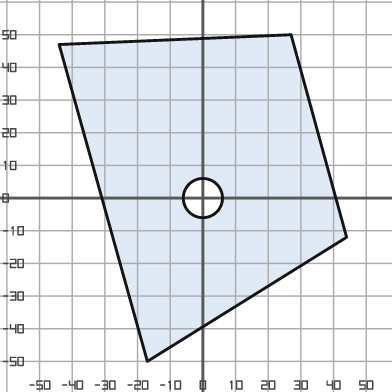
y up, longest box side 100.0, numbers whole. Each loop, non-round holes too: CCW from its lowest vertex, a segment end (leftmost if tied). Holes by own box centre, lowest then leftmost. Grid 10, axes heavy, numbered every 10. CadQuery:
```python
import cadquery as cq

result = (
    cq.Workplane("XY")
    .moveTo(-17.0, -50.0)
    .lineTo(44.0, -12.0)
    .lineTo(27.0, 50.0)
    .lineTo(-44.0, 47.0)
    .close()
    .moveTo(0.0, 0.0)
    .circle(6.0)
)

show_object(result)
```